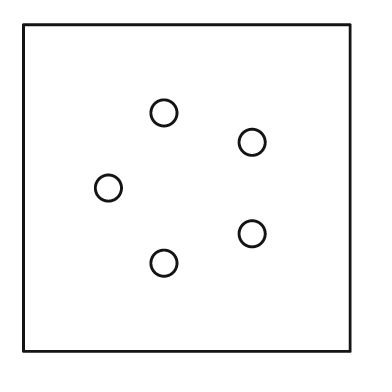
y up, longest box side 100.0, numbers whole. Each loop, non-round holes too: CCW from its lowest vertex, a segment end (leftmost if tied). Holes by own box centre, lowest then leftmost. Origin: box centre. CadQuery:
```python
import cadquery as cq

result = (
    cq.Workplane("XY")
    .moveTo(-50.0, -50.0)
    .lineTo(50.0, -50.0)
    .lineTo(50.0, 50.0)
    .lineTo(-50.0, 50.0)
    .close()
    .moveTo(-7.0, -23.0)
    .circle(4.0)
    .moveTo(20.0, -14.0)
    .circle(4.0)
    .moveTo(-24.0, 0.0)
    .circle(4.0)
    .moveTo(20.0, 14.0)
    .circle(4.0)
    .moveTo(-7.0, 23.0)
    .circle(4.0)
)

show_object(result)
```